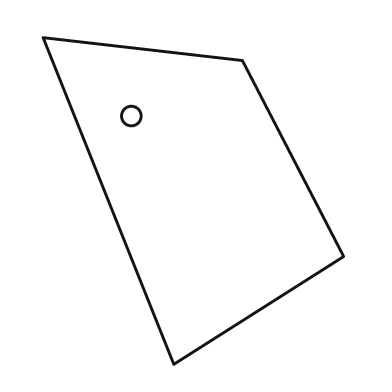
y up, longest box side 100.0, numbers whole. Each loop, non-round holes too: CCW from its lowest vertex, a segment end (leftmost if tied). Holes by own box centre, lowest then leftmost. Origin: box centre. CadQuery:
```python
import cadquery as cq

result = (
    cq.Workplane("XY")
    .moveTo(-6.0, -50.0)
    .lineTo(46.0, -17.0)
    .lineTo(15.0, 43.0)
    .lineTo(-46.0, 50.0)
    .close()
    .moveTo(-19.0, 26.0)
    .circle(3.0)
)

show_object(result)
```